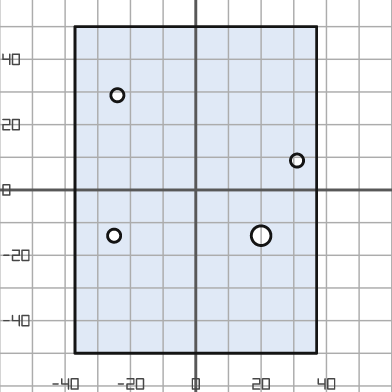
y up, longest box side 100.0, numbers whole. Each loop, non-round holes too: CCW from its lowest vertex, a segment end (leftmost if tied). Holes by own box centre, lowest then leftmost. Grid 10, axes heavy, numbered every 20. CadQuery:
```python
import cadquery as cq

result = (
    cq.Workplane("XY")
    .moveTo(-37.0, -50.0)
    .lineTo(37.0, -50.0)
    .lineTo(37.0, 50.0)
    .lineTo(-37.0, 50.0)
    .close()
    .moveTo(-25.0, -14.0)
    .circle(2.0)
    .moveTo(20.0, -14.0)
    .circle(3.0)
    .moveTo(31.0, 9.0)
    .circle(2.0)
    .moveTo(-24.0, 29.0)
    .circle(2.0)
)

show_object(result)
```